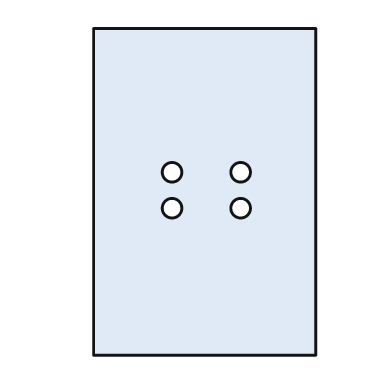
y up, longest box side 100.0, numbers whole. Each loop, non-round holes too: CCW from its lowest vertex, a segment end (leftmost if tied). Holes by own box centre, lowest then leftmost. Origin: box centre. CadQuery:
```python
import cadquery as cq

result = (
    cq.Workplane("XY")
    .moveTo(-34.0, -50.0)
    .lineTo(34.0, -50.0)
    .lineTo(34.0, 50.0)
    .lineTo(-34.0, 50.0)
    .close()
    .moveTo(-10.0, -5.0)
    .circle(3.0)
    .moveTo(11.0, -5.0)
    .circle(3.0)
    .moveTo(-10.0, 6.0)
    .circle(3.0)
    .moveTo(11.0, 6.0)
    .circle(3.0)
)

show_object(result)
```